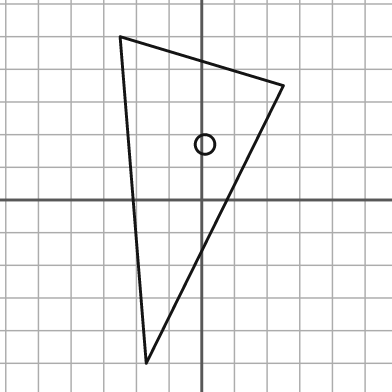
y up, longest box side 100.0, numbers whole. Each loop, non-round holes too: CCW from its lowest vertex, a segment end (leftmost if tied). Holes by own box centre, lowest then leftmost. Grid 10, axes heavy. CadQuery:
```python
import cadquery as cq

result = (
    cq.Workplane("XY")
    .moveTo(-17.0, -50.0)
    .lineTo(25.0, 35.0)
    .lineTo(-25.0, 50.0)
    .close()
    .moveTo(1.0, 17.0)
    .circle(3.0)
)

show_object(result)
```